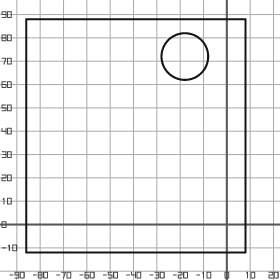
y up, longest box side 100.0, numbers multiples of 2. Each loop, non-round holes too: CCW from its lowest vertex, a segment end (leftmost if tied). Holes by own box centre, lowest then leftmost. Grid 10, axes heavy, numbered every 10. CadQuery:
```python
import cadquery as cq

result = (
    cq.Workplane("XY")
    .moveTo(-86.0, -12.0)
    .lineTo(8.0, -12.0)
    .lineTo(8.0, 88.0)
    .lineTo(-86.0, 88.0)
    .close()
    .moveTo(-18.0, 72.0)
    .circle(10.0)
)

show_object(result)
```